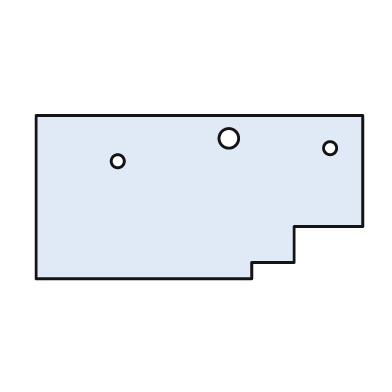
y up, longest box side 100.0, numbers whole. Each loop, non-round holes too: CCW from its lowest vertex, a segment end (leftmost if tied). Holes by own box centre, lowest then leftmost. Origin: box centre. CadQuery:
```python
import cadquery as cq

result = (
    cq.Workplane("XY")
    .moveTo(-50.0, -25.0)
    .lineTo(16.0, -25.0)
    .lineTo(16.0, -20.0)
    .lineTo(29.0, -20.0)
    .lineTo(29.0, -9.0)
    .lineTo(50.0, -9.0)
    .lineTo(50.0, 25.0)
    .lineTo(-50.0, 25.0)
    .close()
    .moveTo(-25.0, 11.0)
    .circle(2.0)
    .moveTo(40.0, 15.0)
    .circle(2.0)
    .moveTo(9.0, 18.0)
    .circle(3.0)
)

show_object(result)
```